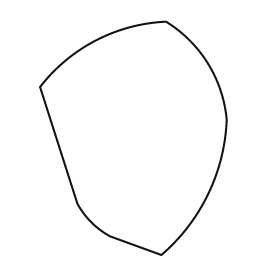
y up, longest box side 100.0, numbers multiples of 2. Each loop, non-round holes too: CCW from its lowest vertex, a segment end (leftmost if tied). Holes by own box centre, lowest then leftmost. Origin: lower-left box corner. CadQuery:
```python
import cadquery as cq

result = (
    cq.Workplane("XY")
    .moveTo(52.0, 0.0)
    .threePointArc((72.0, 26.0), (80.0, 58.0))
    .threePointArc((72.0, 82.0), (54.0, 100.0))
    .threePointArc((24.0, 92.0), (0.0, 72.0))
    .lineTo(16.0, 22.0)
    .threePointArc((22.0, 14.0), (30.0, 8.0))
    .close()
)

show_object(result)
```